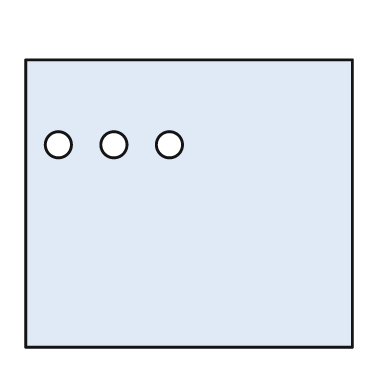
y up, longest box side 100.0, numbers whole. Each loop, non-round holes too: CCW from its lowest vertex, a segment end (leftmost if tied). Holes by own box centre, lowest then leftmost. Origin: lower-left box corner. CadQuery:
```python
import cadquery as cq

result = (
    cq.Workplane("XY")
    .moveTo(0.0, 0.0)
    .lineTo(100.0, 0.0)
    .lineTo(100.0, 88.0)
    .lineTo(0.0, 88.0)
    .close()
    .moveTo(10.0, 62.0)
    .circle(4.0)
    .moveTo(27.0, 62.0)
    .circle(4.0)
    .moveTo(44.0, 62.0)
    .circle(4.0)
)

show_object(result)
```